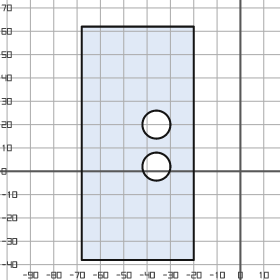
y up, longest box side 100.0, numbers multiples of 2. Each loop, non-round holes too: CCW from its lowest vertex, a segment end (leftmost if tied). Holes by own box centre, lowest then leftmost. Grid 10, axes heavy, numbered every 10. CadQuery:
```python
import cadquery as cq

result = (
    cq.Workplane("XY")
    .moveTo(-68.0, -38.0)
    .lineTo(-20.0, -38.0)
    .lineTo(-20.0, 62.0)
    .lineTo(-68.0, 62.0)
    .close()
    .moveTo(-36.0, 2.0)
    .circle(6.0)
    .moveTo(-36.0, 20.0)
    .circle(6.0)
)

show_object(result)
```